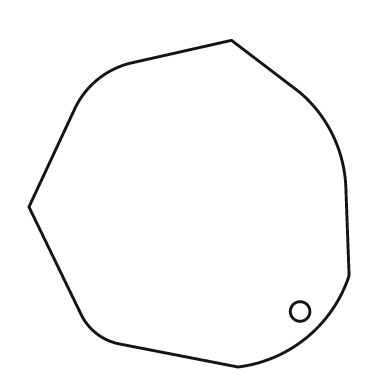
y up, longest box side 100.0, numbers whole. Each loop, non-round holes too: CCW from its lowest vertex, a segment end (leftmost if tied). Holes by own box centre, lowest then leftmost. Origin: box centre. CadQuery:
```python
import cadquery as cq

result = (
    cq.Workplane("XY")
    .moveTo(15.0, -50.0)
    .threePointArc((36.0, -41.0), (49.0, -22.0))
    .lineTo(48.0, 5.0)
    .threePointArc((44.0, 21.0), (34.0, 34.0))
    .lineTo(13.0, 50.0)
    .lineTo(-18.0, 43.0)
    .threePointArc((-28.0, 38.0), (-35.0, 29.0))
    .lineTo(-49.0, -1.0)
    .lineTo(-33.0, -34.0)
    .threePointArc((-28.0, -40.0), (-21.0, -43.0))
    .close()
    .moveTo(34.0, -33.0)
    .circle(3.0)
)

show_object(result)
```